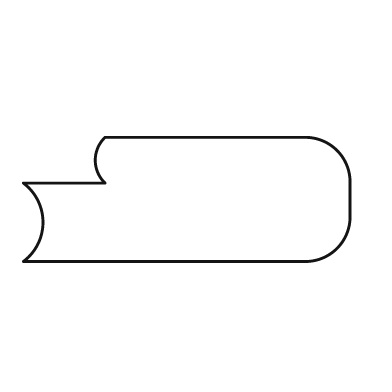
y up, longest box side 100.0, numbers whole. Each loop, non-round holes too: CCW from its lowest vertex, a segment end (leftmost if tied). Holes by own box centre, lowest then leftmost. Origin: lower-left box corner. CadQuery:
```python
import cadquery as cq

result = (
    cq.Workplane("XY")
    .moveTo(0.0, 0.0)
    .lineTo(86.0, 0.0)
    .threePointArc((96.0, 4.0), (100.0, 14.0))
    .lineTo(100.0, 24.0)
    .threePointArc((96.0, 34.0), (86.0, 38.0))
    .lineTo(25.0, 38.0)
    .threePointArc((22.0, 31.0), (25.0, 24.0))
    .lineTo(0.0, 24.0)
    .threePointArc((6.0, 12.0), (0.0, 0.0))
    .close()
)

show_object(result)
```